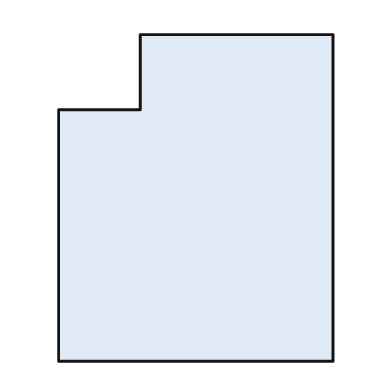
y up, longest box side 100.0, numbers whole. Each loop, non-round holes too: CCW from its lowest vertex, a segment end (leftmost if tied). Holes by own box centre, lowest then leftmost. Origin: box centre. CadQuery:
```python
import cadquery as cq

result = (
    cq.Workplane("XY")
    .moveTo(-42.0, -50.0)
    .lineTo(42.0, -50.0)
    .lineTo(42.0, 50.0)
    .lineTo(-17.0, 50.0)
    .lineTo(-17.0, 27.0)
    .lineTo(-42.0, 27.0)
    .close()
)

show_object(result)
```